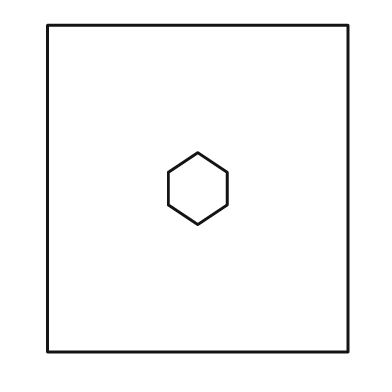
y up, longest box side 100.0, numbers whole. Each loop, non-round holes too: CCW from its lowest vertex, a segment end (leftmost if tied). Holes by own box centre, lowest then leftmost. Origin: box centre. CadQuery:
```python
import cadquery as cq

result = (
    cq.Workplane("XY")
    .moveTo(-46.0, -50.0)
    .lineTo(46.0, -50.0)
    .lineTo(46.0, 50.0)
    .lineTo(-46.0, 50.0)
    .close()
    .moveTo(0.0, -11.0)
    .lineTo(9.0, -5.0)
    .lineTo(9.0, 5.0)
    .lineTo(0.0, 11.0)
    .lineTo(-9.0, 5.0)
    .lineTo(-9.0, -5.0)
    .close()
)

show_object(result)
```